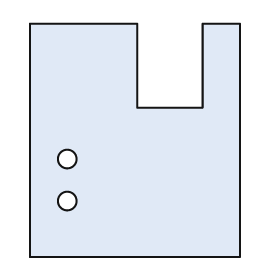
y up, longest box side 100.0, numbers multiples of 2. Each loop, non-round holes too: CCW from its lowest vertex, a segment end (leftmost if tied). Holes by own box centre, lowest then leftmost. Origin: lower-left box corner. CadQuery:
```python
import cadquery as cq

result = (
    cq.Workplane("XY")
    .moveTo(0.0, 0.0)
    .lineTo(90.0, 0.0)
    .lineTo(90.0, 100.0)
    .lineTo(74.0, 100.0)
    .lineTo(74.0, 64.0)
    .lineTo(46.0, 64.0)
    .lineTo(46.0, 100.0)
    .lineTo(0.0, 100.0)
    .close()
    .moveTo(16.0, 24.0)
    .circle(4.0)
    .moveTo(16.0, 42.0)
    .circle(4.0)
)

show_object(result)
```